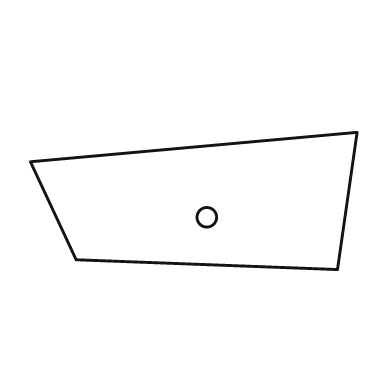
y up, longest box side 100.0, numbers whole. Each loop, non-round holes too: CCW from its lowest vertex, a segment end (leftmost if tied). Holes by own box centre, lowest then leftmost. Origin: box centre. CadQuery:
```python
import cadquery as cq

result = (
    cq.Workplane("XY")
    .moveTo(44.0, -21.0)
    .lineTo(50.0, 21.0)
    .lineTo(-50.0, 12.0)
    .lineTo(-36.0, -18.0)
    .close()
    .moveTo(4.0, -5.0)
    .circle(3.0)
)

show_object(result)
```